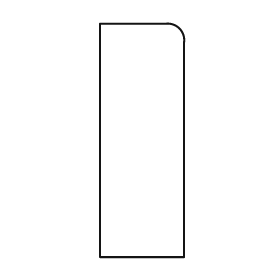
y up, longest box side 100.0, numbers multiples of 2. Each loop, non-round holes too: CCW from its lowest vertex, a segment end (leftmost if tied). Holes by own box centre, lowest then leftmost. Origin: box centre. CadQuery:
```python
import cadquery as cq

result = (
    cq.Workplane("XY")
    .moveTo(-18.0, -50.0)
    .lineTo(18.0, -50.0)
    .lineTo(18.0, 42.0)
    .threePointArc((16.0, 48.0), (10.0, 50.0))
    .lineTo(-18.0, 50.0)
    .close()
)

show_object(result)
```